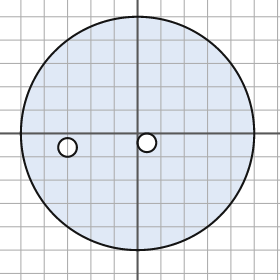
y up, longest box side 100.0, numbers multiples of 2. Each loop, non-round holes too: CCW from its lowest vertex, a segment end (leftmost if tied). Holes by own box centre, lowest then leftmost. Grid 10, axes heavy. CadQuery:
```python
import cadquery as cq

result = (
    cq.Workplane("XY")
    .moveTo(0.0, 0.0)
    .circle(50.0)
    .moveTo(-30.0, -6.0)
    .circle(4.0)
    .moveTo(4.0, -4.0)
    .circle(4.0)
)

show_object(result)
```